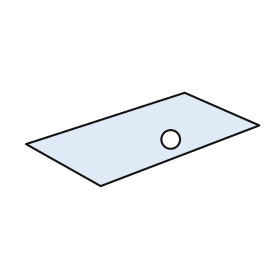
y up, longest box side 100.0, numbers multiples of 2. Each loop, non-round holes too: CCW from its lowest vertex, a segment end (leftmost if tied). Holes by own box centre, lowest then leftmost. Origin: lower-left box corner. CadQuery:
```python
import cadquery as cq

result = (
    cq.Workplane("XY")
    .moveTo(32.0, 0.0)
    .lineTo(100.0, 26.0)
    .lineTo(68.0, 40.0)
    .lineTo(0.0, 18.0)
    .close()
    .moveTo(62.0, 20.0)
    .circle(4.0)
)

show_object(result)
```